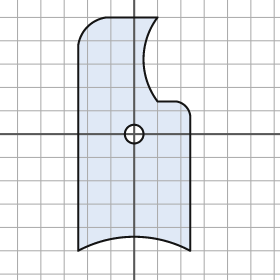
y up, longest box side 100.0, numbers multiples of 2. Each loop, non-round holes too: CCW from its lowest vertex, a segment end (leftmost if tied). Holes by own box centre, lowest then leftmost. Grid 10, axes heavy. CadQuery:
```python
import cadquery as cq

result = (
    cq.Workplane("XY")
    .moveTo(-24.0, -50.0)
    .threePointArc((0.0, -44.0), (24.0, -50.0))
    .lineTo(24.0, 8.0)
    .threePointArc((22.0, 12.0), (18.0, 14.0))
    .lineTo(10.0, 14.0)
    .threePointArc((4.0, 32.0), (10.0, 50.0))
    .lineTo(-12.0, 50.0)
    .threePointArc((-20.0, 46.0), (-24.0, 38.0))
    .close()
    .moveTo(0.0, 0.0)
    .circle(4.0)
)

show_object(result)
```